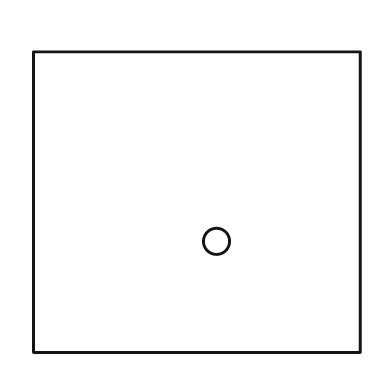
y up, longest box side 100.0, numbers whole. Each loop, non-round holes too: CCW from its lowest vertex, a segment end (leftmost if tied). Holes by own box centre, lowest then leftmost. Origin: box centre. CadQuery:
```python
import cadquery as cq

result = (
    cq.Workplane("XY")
    .moveTo(-50.0, -46.0)
    .lineTo(50.0, -46.0)
    .lineTo(50.0, 46.0)
    .lineTo(-50.0, 46.0)
    .close()
    .moveTo(6.0, -12.0)
    .circle(4.0)
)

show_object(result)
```